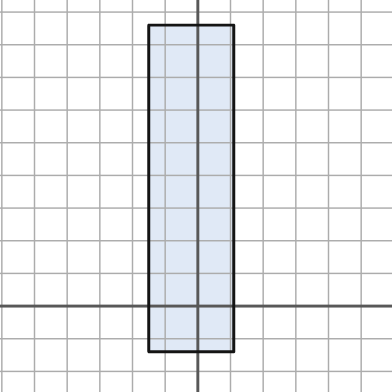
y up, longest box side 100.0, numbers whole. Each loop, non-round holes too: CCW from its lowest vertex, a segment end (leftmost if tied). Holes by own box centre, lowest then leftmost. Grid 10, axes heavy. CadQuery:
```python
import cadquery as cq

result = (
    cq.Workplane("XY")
    .moveTo(-15.0, -14.0)
    .lineTo(11.0, -14.0)
    .lineTo(11.0, 86.0)
    .lineTo(-15.0, 86.0)
    .close()
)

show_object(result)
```